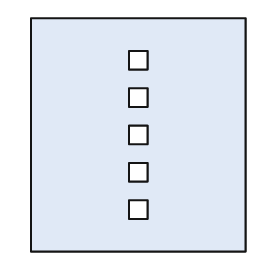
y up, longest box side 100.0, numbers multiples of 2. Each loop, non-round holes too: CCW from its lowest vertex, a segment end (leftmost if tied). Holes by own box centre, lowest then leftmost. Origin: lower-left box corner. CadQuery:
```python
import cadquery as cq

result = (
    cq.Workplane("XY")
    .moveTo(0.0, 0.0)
    .lineTo(92.0, 0.0)
    .lineTo(92.0, 100.0)
    .lineTo(0.0, 100.0)
    .close()
    .moveTo(42.0, 14.0)
    .lineTo(50.0, 14.0)
    .lineTo(50.0, 22.0)
    .lineTo(42.0, 22.0)
    .close()
    .moveTo(42.0, 30.0)
    .lineTo(50.0, 30.0)
    .lineTo(50.0, 38.0)
    .lineTo(42.0, 38.0)
    .close()
    .moveTo(42.0, 46.0)
    .lineTo(50.0, 46.0)
    .lineTo(50.0, 54.0)
    .lineTo(42.0, 54.0)
    .close()
    .moveTo(42.0, 62.0)
    .lineTo(50.0, 62.0)
    .lineTo(50.0, 70.0)
    .lineTo(42.0, 70.0)
    .close()
    .moveTo(42.0, 78.0)
    .lineTo(50.0, 78.0)
    .lineTo(50.0, 86.0)
    .lineTo(42.0, 86.0)
    .close()
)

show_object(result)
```